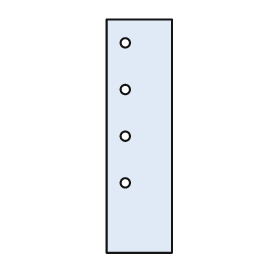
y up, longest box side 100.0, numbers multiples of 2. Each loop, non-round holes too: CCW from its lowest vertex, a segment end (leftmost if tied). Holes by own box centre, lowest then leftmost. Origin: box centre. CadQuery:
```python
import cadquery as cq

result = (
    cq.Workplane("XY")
    .moveTo(-14.0, -50.0)
    .lineTo(14.0, -50.0)
    .lineTo(14.0, 50.0)
    .lineTo(-14.0, 50.0)
    .close()
    .moveTo(-6.0, -20.0)
    .circle(2.0)
    .moveTo(-6.0, 0.0)
    .circle(2.0)
    .moveTo(-6.0, 20.0)
    .circle(2.0)
    .moveTo(-6.0, 40.0)
    .circle(2.0)
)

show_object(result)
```